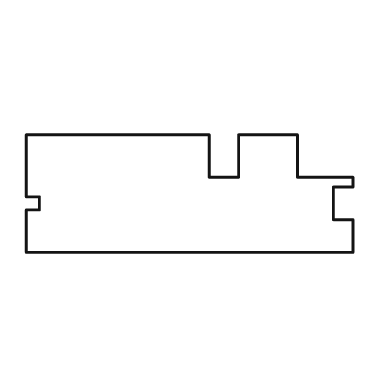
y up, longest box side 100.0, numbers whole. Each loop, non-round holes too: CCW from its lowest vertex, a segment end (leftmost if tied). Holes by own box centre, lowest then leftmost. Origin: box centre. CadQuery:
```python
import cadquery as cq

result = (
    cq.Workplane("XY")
    .moveTo(-50.0, -18.0)
    .lineTo(50.0, -18.0)
    .lineTo(50.0, -8.0)
    .lineTo(44.0, -8.0)
    .lineTo(44.0, 2.0)
    .lineTo(50.0, 2.0)
    .lineTo(50.0, 5.0)
    .lineTo(33.0, 5.0)
    .lineTo(33.0, 18.0)
    .lineTo(15.0, 18.0)
    .lineTo(15.0, 5.0)
    .lineTo(6.0, 5.0)
    .lineTo(6.0, 18.0)
    .lineTo(-50.0, 18.0)
    .lineTo(-50.0, -1.0)
    .lineTo(-46.0, -1.0)
    .lineTo(-46.0, -5.0)
    .lineTo(-50.0, -5.0)
    .close()
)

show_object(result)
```